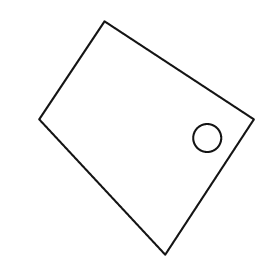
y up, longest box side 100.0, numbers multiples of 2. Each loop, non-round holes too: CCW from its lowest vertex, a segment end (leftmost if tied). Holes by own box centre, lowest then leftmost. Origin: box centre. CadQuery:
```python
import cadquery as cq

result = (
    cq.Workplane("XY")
    .moveTo(8.0, -50.0)
    .lineTo(46.0, 8.0)
    .lineTo(-18.0, 50.0)
    .lineTo(-46.0, 8.0)
    .close()
    .moveTo(26.0, 0.0)
    .circle(6.0)
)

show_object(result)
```